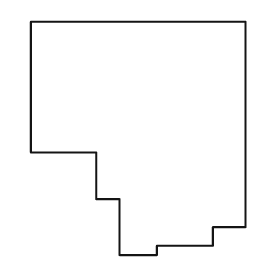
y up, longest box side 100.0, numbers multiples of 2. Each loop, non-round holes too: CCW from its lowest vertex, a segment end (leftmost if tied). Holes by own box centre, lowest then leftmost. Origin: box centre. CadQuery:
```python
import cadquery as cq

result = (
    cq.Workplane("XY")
    .moveTo(-8.0, -50.0)
    .lineTo(8.0, -50.0)
    .lineTo(8.0, -46.0)
    .lineTo(32.0, -46.0)
    .lineTo(32.0, -38.0)
    .lineTo(46.0, -38.0)
    .lineTo(46.0, 50.0)
    .lineTo(-46.0, 50.0)
    .lineTo(-46.0, -6.0)
    .lineTo(-18.0, -6.0)
    .lineTo(-18.0, -26.0)
    .lineTo(-8.0, -26.0)
    .close()
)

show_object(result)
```